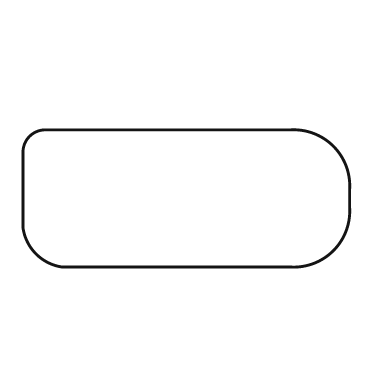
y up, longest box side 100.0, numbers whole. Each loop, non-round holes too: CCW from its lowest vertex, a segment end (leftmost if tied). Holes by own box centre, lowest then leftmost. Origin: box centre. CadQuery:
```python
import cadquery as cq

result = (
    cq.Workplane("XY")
    .moveTo(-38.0, -21.0)
    .lineTo(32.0, -21.0)
    .threePointArc((45.0, -16.0), (50.0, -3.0))
    .lineTo(50.0, 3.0)
    .threePointArc((45.0, 16.0), (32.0, 21.0))
    .lineTo(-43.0, 21.0)
    .threePointArc((-48.0, 19.0), (-50.0, 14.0))
    .lineTo(-50.0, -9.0)
    .threePointArc((-46.0, -17.0), (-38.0, -21.0))
    .close()
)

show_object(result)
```